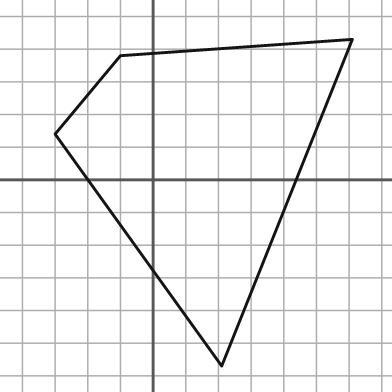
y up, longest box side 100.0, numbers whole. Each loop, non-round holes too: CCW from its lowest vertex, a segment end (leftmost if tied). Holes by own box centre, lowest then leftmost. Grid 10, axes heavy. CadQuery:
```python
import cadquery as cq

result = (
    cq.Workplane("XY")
    .moveTo(21.0, -57.0)
    .lineTo(61.0, 43.0)
    .lineTo(-10.0, 38.0)
    .lineTo(-30.0, 14.0)
    .close()
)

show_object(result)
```